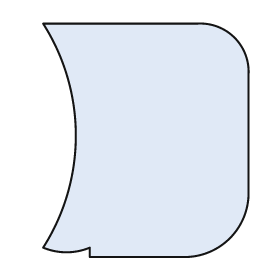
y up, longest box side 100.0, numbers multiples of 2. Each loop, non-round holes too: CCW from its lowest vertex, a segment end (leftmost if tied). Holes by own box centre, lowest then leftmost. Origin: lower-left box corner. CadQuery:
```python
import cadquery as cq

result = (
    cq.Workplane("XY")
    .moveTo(20.0, 0.0)
    .lineTo(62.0, 0.0)
    .threePointArc((80.0, 8.0), (88.0, 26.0))
    .lineTo(88.0, 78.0)
    .threePointArc((82.0, 94.0), (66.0, 100.0))
    .lineTo(0.0, 100.0)
    .threePointArc((14.0, 52.0), (0.0, 4.0))
    .threePointArc((10.0, 2.0), (20.0, 4.0))
    .close()
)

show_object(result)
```